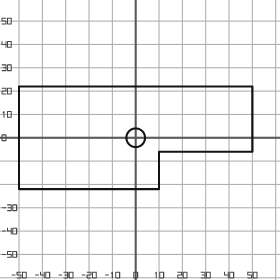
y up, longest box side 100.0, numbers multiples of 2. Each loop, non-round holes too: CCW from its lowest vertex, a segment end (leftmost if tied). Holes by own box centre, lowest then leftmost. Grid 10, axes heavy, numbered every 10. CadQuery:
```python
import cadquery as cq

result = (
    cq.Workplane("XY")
    .moveTo(-50.0, -22.0)
    .lineTo(10.0, -22.0)
    .lineTo(10.0, -6.0)
    .lineTo(50.0, -6.0)
    .lineTo(50.0, 22.0)
    .lineTo(-50.0, 22.0)
    .close()
    .moveTo(0.0, 0.0)
    .circle(4.0)
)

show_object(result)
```